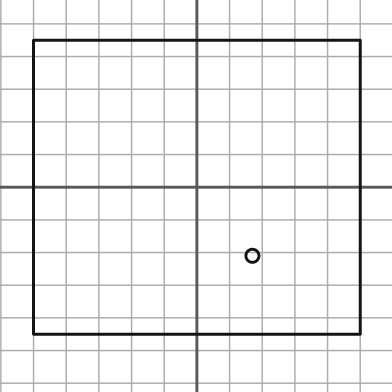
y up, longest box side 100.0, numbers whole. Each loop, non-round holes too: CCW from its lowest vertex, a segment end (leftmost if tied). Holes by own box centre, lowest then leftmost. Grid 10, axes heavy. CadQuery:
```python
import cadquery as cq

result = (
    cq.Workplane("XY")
    .moveTo(-50.0, -45.0)
    .lineTo(50.0, -45.0)
    .lineTo(50.0, 45.0)
    .lineTo(-50.0, 45.0)
    .close()
    .moveTo(17.0, -21.0)
    .circle(2.0)
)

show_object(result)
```